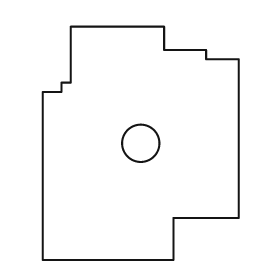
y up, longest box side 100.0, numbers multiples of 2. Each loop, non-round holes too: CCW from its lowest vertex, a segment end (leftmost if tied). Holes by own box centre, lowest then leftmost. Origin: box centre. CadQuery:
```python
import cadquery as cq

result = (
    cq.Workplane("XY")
    .moveTo(-42.0, -50.0)
    .lineTo(14.0, -50.0)
    .lineTo(14.0, -32.0)
    .lineTo(42.0, -32.0)
    .lineTo(42.0, 36.0)
    .lineTo(28.0, 36.0)
    .lineTo(28.0, 40.0)
    .lineTo(10.0, 40.0)
    .lineTo(10.0, 50.0)
    .lineTo(-30.0, 50.0)
    .lineTo(-30.0, 26.0)
    .lineTo(-34.0, 26.0)
    .lineTo(-34.0, 22.0)
    .lineTo(-42.0, 22.0)
    .close()
    .moveTo(0.0, 0.0)
    .circle(8.0)
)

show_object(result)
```